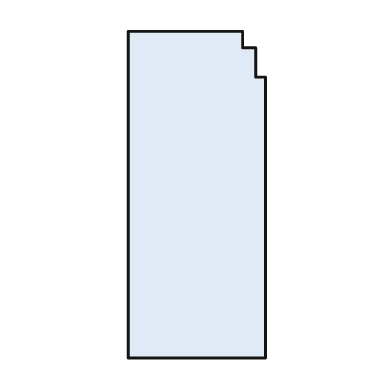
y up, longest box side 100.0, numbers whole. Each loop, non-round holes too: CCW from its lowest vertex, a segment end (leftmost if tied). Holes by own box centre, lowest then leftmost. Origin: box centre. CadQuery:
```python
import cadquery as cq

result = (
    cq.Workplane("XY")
    .moveTo(-21.0, -50.0)
    .lineTo(21.0, -50.0)
    .lineTo(21.0, 36.0)
    .lineTo(18.0, 36.0)
    .lineTo(18.0, 45.0)
    .lineTo(14.0, 45.0)
    .lineTo(14.0, 50.0)
    .lineTo(-21.0, 50.0)
    .close()
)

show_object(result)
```